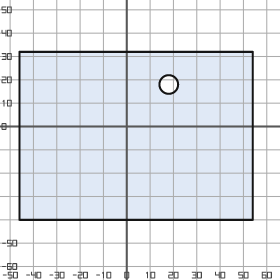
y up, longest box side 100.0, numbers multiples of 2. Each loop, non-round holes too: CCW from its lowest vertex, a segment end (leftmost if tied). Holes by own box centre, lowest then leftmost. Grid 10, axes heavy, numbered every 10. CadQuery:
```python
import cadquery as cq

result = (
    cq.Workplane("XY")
    .moveTo(-46.0, -40.0)
    .lineTo(54.0, -40.0)
    .lineTo(54.0, 32.0)
    .lineTo(-46.0, 32.0)
    .close()
    .moveTo(18.0, 18.0)
    .circle(4.0)
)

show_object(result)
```